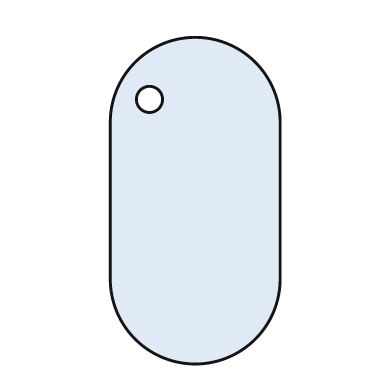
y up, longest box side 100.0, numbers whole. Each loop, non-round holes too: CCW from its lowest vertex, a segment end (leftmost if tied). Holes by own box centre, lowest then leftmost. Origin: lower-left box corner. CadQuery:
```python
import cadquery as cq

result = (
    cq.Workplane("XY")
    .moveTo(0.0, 26.0)
    .threePointArc((26.0, 0.0), (52.0, 26.0))
    .lineTo(52.0, 74.0)
    .threePointArc((26.0, 100.0), (0.0, 74.0))
    .close()
    .moveTo(12.0, 81.0)
    .circle(4.0)
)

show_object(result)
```